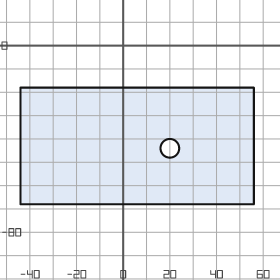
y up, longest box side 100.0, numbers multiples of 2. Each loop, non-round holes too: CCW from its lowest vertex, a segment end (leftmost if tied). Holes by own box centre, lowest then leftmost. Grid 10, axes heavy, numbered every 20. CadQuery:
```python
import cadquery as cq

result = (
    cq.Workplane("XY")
    .moveTo(-44.0, -68.0)
    .lineTo(56.0, -68.0)
    .lineTo(56.0, -18.0)
    .lineTo(-44.0, -18.0)
    .close()
    .moveTo(20.0, -44.0)
    .circle(4.0)
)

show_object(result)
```